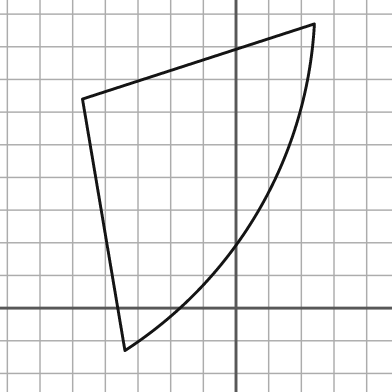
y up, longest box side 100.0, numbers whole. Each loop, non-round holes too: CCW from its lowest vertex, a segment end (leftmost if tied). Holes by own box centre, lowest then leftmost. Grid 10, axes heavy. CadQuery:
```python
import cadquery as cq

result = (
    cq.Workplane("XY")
    .moveTo(-34.0, -13.0)
    .threePointArc((7.0, 30.0), (24.0, 87.0))
    .lineTo(-47.0, 64.0)
    .close()
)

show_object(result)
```